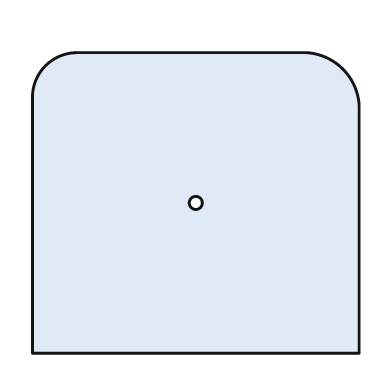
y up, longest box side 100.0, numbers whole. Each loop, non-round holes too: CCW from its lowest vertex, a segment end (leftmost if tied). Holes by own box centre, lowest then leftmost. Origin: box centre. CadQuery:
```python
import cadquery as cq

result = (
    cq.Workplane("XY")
    .moveTo(-50.0, -46.0)
    .lineTo(50.0, -46.0)
    .lineTo(50.0, 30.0)
    .threePointArc((45.0, 41.0), (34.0, 46.0))
    .lineTo(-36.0, 46.0)
    .threePointArc((-46.0, 42.0), (-50.0, 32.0))
    .close()
    .moveTo(0.0, 0.0)
    .circle(2.0)
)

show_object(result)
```